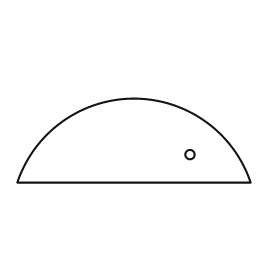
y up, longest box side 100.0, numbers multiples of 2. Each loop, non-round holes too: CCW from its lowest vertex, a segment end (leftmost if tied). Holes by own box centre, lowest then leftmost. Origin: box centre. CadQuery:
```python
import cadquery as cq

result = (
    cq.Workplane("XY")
    .moveTo(-50.0, -18.0)
    .lineTo(50.0, -18.0)
    .threePointArc((0.0, 18.0), (-50.0, -18.0))
    .close()
    .moveTo(24.0, -6.0)
    .circle(2.0)
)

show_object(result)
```